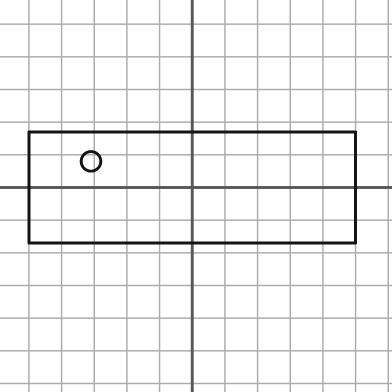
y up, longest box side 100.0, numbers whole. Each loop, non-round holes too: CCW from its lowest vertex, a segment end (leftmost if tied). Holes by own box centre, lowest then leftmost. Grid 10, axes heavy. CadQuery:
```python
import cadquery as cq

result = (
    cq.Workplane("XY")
    .moveTo(-50.0, -17.0)
    .lineTo(50.0, -17.0)
    .lineTo(50.0, 17.0)
    .lineTo(-50.0, 17.0)
    .close()
    .moveTo(-31.0, 8.0)
    .circle(3.0)
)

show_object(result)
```